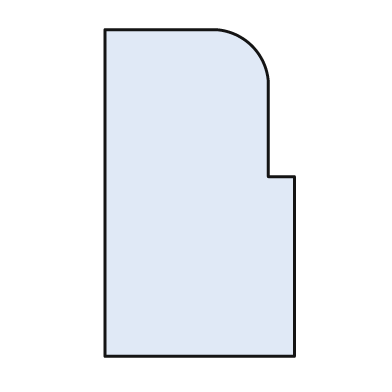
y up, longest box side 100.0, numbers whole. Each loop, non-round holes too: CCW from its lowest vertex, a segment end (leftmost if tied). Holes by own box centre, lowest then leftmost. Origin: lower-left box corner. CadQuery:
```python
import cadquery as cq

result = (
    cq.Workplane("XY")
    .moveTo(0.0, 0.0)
    .lineTo(58.0, 0.0)
    .lineTo(58.0, 55.0)
    .lineTo(50.0, 55.0)
    .lineTo(50.0, 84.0)
    .threePointArc((45.0, 95.0), (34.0, 100.0))
    .lineTo(0.0, 100.0)
    .close()
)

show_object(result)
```